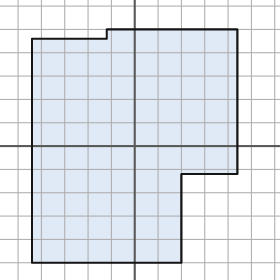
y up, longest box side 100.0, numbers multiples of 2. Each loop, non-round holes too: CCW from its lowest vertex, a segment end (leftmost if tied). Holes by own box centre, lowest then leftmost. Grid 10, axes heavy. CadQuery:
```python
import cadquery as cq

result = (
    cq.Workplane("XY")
    .moveTo(-44.0, -50.0)
    .lineTo(20.0, -50.0)
    .lineTo(20.0, -12.0)
    .lineTo(44.0, -12.0)
    .lineTo(44.0, 50.0)
    .lineTo(-12.0, 50.0)
    .lineTo(-12.0, 46.0)
    .lineTo(-44.0, 46.0)
    .close()
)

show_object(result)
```